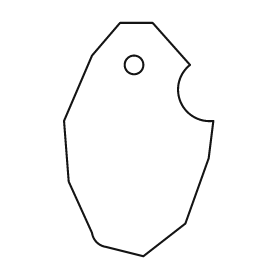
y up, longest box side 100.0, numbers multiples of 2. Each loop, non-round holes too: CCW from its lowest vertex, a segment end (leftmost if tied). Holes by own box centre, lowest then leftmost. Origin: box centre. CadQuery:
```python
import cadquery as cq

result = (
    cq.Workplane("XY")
    .moveTo(2.0, -50.0)
    .lineTo(20.0, -36.0)
    .lineTo(30.0, -8.0)
    .lineTo(32.0, 8.0)
    .threePointArc((18.0, 16.0), (22.0, 32.0))
    .lineTo(6.0, 50.0)
    .lineTo(-8.0, 50.0)
    .lineTo(-20.0, 36.0)
    .lineTo(-32.0, 8.0)
    .lineTo(-30.0, -18.0)
    .lineTo(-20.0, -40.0)
    .threePointArc((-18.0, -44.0), (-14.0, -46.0))
    .close()
    .moveTo(-2.0, 32.0)
    .circle(4.0)
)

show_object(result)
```